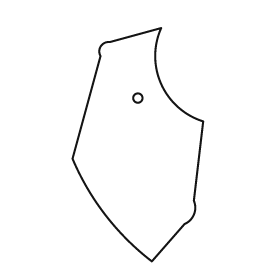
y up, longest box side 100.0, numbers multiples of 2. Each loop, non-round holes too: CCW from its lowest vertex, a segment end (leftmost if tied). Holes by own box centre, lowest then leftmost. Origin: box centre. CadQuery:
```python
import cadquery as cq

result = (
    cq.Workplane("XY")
    .moveTo(6.0, -50.0)
    .lineTo(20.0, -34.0)
    .threePointArc((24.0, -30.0), (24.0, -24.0))
    .lineTo(28.0, 10.0)
    .threePointArc((10.0, 26.0), (10.0, 50.0))
    .lineTo(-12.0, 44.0)
    .threePointArc((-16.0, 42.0), (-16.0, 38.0))
    .lineTo(-28.0, -6.0)
    .threePointArc((-14.0, -30.0), (6.0, -50.0))
    .close()
    .moveTo(0.0, 20.0)
    .circle(2.0)
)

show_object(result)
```